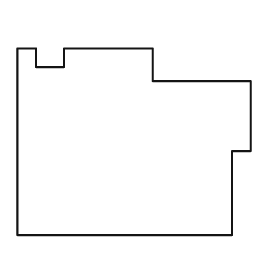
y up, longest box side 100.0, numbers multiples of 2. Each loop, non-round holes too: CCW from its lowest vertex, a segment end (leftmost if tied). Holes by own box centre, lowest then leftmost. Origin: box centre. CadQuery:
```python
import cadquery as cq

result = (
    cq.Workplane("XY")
    .moveTo(-50.0, -40.0)
    .lineTo(42.0, -40.0)
    .lineTo(42.0, -4.0)
    .lineTo(50.0, -4.0)
    .lineTo(50.0, 26.0)
    .lineTo(8.0, 26.0)
    .lineTo(8.0, 40.0)
    .lineTo(-30.0, 40.0)
    .lineTo(-30.0, 32.0)
    .lineTo(-42.0, 32.0)
    .lineTo(-42.0, 40.0)
    .lineTo(-50.0, 40.0)
    .close()
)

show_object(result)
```